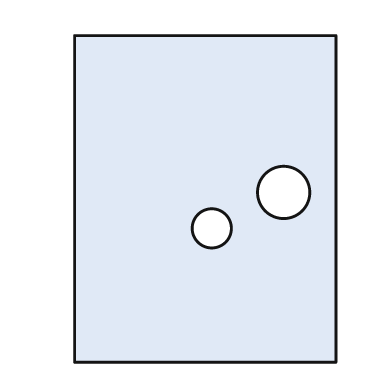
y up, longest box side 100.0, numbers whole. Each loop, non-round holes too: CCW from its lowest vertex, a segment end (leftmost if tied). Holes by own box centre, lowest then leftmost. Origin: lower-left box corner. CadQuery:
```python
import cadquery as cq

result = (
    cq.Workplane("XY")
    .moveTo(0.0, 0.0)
    .lineTo(80.0, 0.0)
    .lineTo(80.0, 100.0)
    .lineTo(0.0, 100.0)
    .close()
    .moveTo(42.0, 41.0)
    .circle(6.0)
    .moveTo(64.0, 52.0)
    .circle(8.0)
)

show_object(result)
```